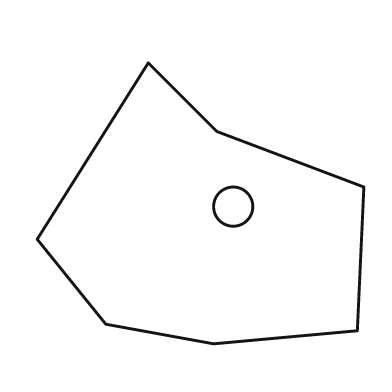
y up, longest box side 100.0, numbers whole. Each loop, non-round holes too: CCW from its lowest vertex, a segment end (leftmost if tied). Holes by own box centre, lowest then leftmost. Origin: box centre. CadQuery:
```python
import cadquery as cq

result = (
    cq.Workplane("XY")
    .moveTo(4.0, -43.0)
    .lineTo(48.0, -39.0)
    .lineTo(50.0, 5.0)
    .lineTo(5.0, 22.0)
    .lineTo(-16.0, 43.0)
    .lineTo(-50.0, -11.0)
    .lineTo(-29.0, -37.0)
    .close()
    .moveTo(10.0, -1.0)
    .circle(6.0)
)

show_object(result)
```